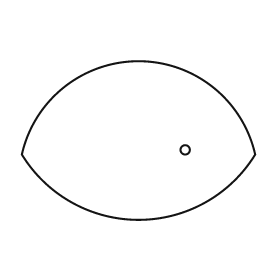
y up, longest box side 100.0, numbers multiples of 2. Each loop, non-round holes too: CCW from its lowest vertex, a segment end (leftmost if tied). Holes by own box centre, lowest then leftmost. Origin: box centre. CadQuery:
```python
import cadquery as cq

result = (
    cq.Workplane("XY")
    .moveTo(-50.0, -6.0)
    .threePointArc((0.0, -34.0), (50.0, -6.0))
    .threePointArc((0.0, 34.0), (-50.0, -6.0))
    .close()
    .moveTo(20.0, -4.0)
    .circle(2.0)
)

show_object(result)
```